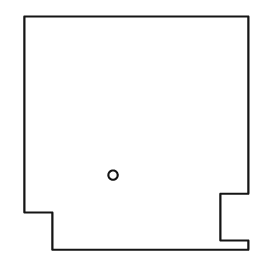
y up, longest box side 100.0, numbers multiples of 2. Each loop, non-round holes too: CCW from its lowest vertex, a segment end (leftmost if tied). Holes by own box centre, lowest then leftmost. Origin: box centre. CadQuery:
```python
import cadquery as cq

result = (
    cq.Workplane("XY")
    .moveTo(-36.0, -50.0)
    .lineTo(48.0, -50.0)
    .lineTo(48.0, -46.0)
    .lineTo(36.0, -46.0)
    .lineTo(36.0, -26.0)
    .lineTo(48.0, -26.0)
    .lineTo(48.0, 50.0)
    .lineTo(-48.0, 50.0)
    .lineTo(-48.0, -34.0)
    .lineTo(-36.0, -34.0)
    .close()
    .moveTo(-10.0, -18.0)
    .circle(2.0)
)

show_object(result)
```